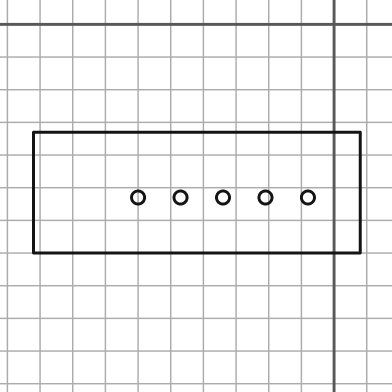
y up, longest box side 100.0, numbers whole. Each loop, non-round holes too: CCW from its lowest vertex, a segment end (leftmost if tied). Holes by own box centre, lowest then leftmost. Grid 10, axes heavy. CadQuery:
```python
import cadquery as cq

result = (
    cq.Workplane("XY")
    .moveTo(-92.0, -70.0)
    .lineTo(8.0, -70.0)
    .lineTo(8.0, -33.0)
    .lineTo(-92.0, -33.0)
    .close()
    .moveTo(-60.0, -53.0)
    .circle(2.0)
    .moveTo(-47.0, -53.0)
    .circle(2.0)
    .moveTo(-34.0, -53.0)
    .circle(2.0)
    .moveTo(-21.0, -53.0)
    .circle(2.0)
    .moveTo(-8.0, -53.0)
    .circle(2.0)
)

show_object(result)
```